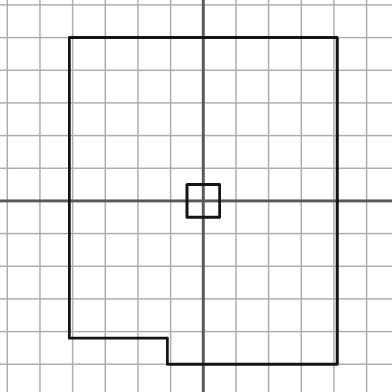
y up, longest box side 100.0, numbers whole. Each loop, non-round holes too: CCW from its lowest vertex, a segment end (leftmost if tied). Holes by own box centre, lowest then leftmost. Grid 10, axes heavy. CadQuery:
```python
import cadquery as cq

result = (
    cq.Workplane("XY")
    .moveTo(-11.0, -50.0)
    .lineTo(41.0, -50.0)
    .lineTo(41.0, 50.0)
    .lineTo(-41.0, 50.0)
    .lineTo(-41.0, -42.0)
    .lineTo(-11.0, -42.0)
    .close()
    .moveTo(-5.0, -5.0)
    .lineTo(5.0, -5.0)
    .lineTo(5.0, 5.0)
    .lineTo(-5.0, 5.0)
    .close()
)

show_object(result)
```